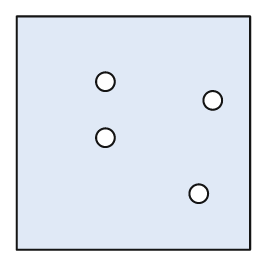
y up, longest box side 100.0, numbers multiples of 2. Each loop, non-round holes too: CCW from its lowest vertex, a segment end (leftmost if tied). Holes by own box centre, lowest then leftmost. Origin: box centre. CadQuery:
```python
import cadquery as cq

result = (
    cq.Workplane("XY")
    .moveTo(-50.0, -50.0)
    .lineTo(50.0, -50.0)
    .lineTo(50.0, 50.0)
    .lineTo(-50.0, 50.0)
    .close()
    .moveTo(28.0, -26.0)
    .circle(4.0)
    .moveTo(-12.0, -2.0)
    .circle(4.0)
    .moveTo(34.0, 14.0)
    .circle(4.0)
    .moveTo(-12.0, 22.0)
    .circle(4.0)
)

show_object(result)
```